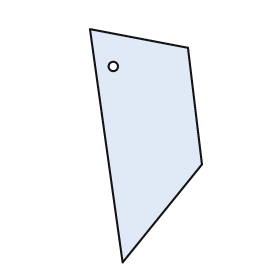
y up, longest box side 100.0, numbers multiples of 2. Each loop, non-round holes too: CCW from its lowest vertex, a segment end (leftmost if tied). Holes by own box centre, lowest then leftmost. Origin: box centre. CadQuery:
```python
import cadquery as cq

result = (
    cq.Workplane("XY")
    .moveTo(-10.0, -50.0)
    .lineTo(24.0, -8.0)
    .lineTo(18.0, 42.0)
    .lineTo(-24.0, 50.0)
    .close()
    .moveTo(-14.0, 34.0)
    .circle(2.0)
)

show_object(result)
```